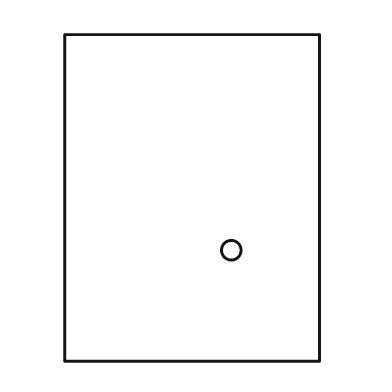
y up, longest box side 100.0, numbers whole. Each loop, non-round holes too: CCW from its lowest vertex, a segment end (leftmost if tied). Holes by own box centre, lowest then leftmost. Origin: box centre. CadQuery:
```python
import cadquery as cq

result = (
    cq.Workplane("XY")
    .moveTo(-39.0, -50.0)
    .lineTo(39.0, -50.0)
    .lineTo(39.0, 50.0)
    .lineTo(-39.0, 50.0)
    .close()
    .moveTo(12.0, -16.0)
    .circle(3.0)
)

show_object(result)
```